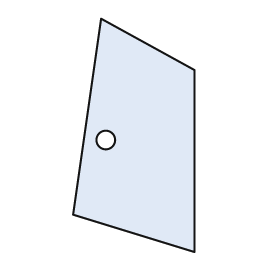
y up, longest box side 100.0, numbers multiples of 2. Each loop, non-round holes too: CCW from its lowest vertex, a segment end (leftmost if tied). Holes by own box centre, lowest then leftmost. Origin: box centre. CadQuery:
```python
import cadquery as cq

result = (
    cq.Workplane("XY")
    .moveTo(26.0, -50.0)
    .lineTo(26.0, 28.0)
    .lineTo(-14.0, 50.0)
    .lineTo(-26.0, -34.0)
    .close()
    .moveTo(-12.0, -2.0)
    .circle(4.0)
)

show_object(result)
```